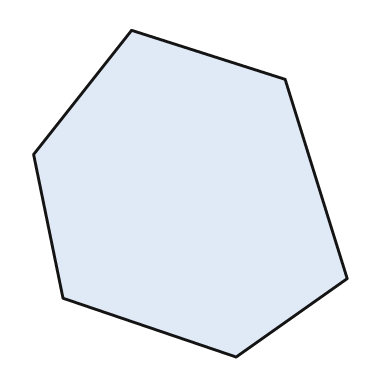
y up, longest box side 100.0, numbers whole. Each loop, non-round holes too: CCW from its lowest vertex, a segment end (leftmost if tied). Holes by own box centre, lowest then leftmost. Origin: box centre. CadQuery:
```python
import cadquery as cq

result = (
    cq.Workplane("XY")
    .moveTo(14.0, -50.0)
    .lineTo(48.0, -26.0)
    .lineTo(29.0, 35.0)
    .lineTo(-18.0, 50.0)
    .lineTo(-48.0, 12.0)
    .lineTo(-39.0, -32.0)
    .close()
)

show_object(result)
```